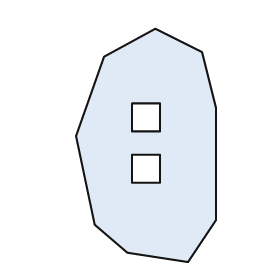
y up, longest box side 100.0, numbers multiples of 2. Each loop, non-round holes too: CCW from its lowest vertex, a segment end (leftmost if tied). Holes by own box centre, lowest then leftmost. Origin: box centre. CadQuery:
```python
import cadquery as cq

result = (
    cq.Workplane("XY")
    .moveTo(18.0, -50.0)
    .lineTo(30.0, -32.0)
    .lineTo(30.0, 16.0)
    .lineTo(24.0, 40.0)
    .lineTo(4.0, 50.0)
    .lineTo(-18.0, 38.0)
    .lineTo(-30.0, 4.0)
    .lineTo(-22.0, -34.0)
    .lineTo(-8.0, -46.0)
    .close()
    .moveTo(-6.0, -16.0)
    .lineTo(6.0, -16.0)
    .lineTo(6.0, -4.0)
    .lineTo(-6.0, -4.0)
    .close()
    .moveTo(-6.0, 6.0)
    .lineTo(6.0, 6.0)
    .lineTo(6.0, 18.0)
    .lineTo(-6.0, 18.0)
    .close()
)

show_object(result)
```